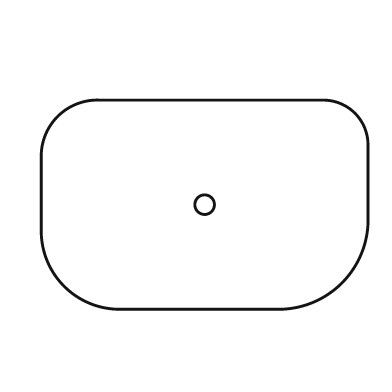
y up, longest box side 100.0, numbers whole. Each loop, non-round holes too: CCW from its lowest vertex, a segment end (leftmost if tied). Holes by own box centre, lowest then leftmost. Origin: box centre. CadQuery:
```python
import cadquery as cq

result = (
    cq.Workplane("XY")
    .moveTo(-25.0, -32.0)
    .lineTo(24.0, -32.0)
    .threePointArc((42.0, -24.0), (50.0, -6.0))
    .lineTo(50.0, 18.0)
    .threePointArc((46.0, 28.0), (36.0, 32.0))
    .lineTo(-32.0, 32.0)
    .threePointArc((-45.0, 27.0), (-50.0, 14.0))
    .lineTo(-50.0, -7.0)
    .threePointArc((-43.0, -25.0), (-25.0, -32.0))
    .close()
    .moveTo(0.0, 0.0)
    .circle(3.0)
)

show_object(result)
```